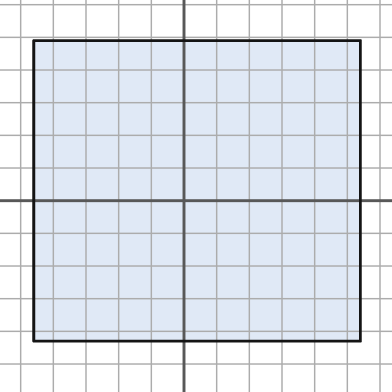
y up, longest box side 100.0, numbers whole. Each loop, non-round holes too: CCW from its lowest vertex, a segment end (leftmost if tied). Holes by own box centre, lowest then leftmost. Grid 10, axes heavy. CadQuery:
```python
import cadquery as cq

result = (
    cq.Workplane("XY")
    .moveTo(-46.0, -43.0)
    .lineTo(54.0, -43.0)
    .lineTo(54.0, 49.0)
    .lineTo(-46.0, 49.0)
    .close()
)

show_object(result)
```